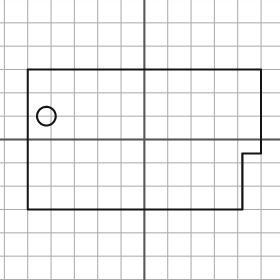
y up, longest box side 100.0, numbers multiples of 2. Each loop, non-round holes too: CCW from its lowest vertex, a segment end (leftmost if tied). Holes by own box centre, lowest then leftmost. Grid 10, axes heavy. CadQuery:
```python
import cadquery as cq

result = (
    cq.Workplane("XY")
    .moveTo(-50.0, -30.0)
    .lineTo(42.0, -30.0)
    .lineTo(42.0, -6.0)
    .lineTo(50.0, -6.0)
    .lineTo(50.0, 30.0)
    .lineTo(-50.0, 30.0)
    .close()
    .moveTo(-42.0, 10.0)
    .circle(4.0)
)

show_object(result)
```